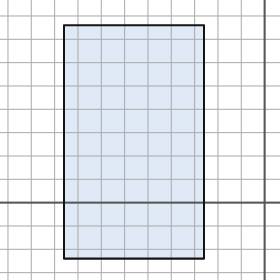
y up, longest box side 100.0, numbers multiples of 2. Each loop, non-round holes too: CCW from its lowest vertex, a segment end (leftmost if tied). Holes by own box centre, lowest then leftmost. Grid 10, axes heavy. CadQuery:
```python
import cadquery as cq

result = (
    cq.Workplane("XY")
    .moveTo(-86.0, -24.0)
    .lineTo(-26.0, -24.0)
    .lineTo(-26.0, 76.0)
    .lineTo(-86.0, 76.0)
    .close()
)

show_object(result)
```